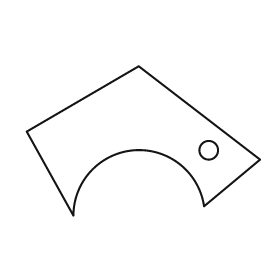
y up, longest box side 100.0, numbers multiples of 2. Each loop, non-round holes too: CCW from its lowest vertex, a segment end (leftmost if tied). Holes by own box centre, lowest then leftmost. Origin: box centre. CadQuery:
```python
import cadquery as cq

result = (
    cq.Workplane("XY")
    .moveTo(-30.0, -32.0)
    .threePointArc((-4.0, -4.0), (26.0, -28.0))
    .lineTo(50.0, -8.0)
    .lineTo(-2.0, 32.0)
    .lineTo(-50.0, 4.0)
    .close()
    .moveTo(28.0, -4.0)
    .circle(4.0)
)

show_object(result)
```